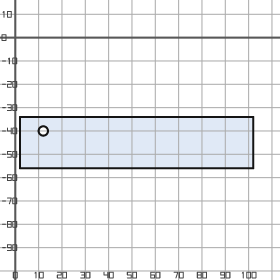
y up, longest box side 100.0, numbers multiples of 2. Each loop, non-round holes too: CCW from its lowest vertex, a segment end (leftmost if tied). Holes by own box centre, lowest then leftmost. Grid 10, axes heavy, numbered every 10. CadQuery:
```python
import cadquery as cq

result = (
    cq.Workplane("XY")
    .moveTo(2.0, -56.0)
    .lineTo(102.0, -56.0)
    .lineTo(102.0, -34.0)
    .lineTo(2.0, -34.0)
    .close()
    .moveTo(12.0, -40.0)
    .circle(2.0)
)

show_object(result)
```